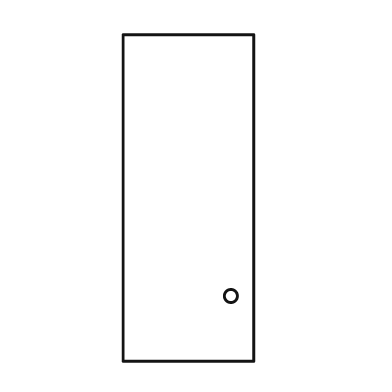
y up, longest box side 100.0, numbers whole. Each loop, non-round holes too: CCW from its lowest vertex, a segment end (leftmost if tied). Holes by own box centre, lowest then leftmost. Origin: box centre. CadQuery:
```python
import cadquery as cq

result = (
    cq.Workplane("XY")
    .moveTo(-20.0, -50.0)
    .lineTo(20.0, -50.0)
    .lineTo(20.0, 50.0)
    .lineTo(-20.0, 50.0)
    .close()
    .moveTo(13.0, -30.0)
    .circle(2.0)
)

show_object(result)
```